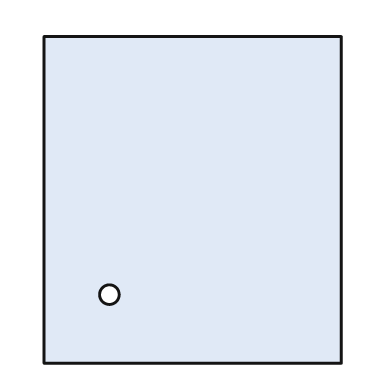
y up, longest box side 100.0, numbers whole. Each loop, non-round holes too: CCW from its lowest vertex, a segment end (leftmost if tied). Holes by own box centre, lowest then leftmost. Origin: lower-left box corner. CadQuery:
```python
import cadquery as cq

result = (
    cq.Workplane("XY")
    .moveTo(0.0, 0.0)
    .lineTo(91.0, 0.0)
    .lineTo(91.0, 100.0)
    .lineTo(0.0, 100.0)
    .close()
    .moveTo(20.0, 21.0)
    .circle(3.0)
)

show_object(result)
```